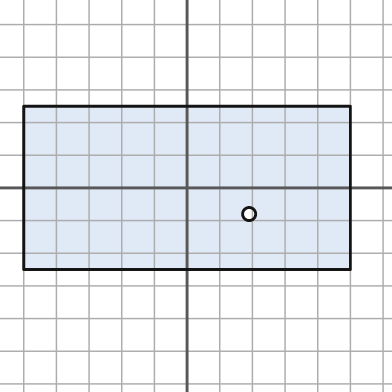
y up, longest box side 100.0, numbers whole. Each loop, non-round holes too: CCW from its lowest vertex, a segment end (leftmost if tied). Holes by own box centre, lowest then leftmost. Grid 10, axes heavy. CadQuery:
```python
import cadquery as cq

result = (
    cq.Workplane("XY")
    .moveTo(-50.0, -25.0)
    .lineTo(50.0, -25.0)
    .lineTo(50.0, 25.0)
    .lineTo(-50.0, 25.0)
    .close()
    .moveTo(19.0, -8.0)
    .circle(2.0)
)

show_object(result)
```